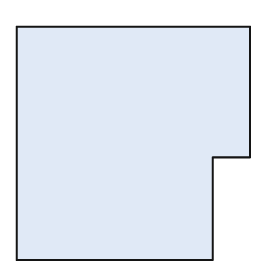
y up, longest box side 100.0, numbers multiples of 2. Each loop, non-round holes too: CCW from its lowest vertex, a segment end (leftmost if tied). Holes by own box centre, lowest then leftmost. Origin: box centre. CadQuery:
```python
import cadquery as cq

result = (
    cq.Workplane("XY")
    .moveTo(-50.0, -50.0)
    .lineTo(34.0, -50.0)
    .lineTo(34.0, -6.0)
    .lineTo(50.0, -6.0)
    .lineTo(50.0, 50.0)
    .lineTo(-50.0, 50.0)
    .close()
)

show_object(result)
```